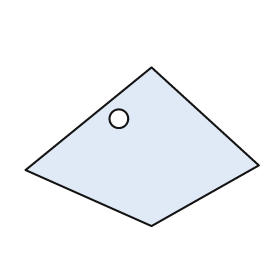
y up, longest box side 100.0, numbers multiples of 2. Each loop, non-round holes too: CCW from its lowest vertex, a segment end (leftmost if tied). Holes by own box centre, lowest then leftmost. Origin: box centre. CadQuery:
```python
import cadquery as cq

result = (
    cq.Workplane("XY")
    .moveTo(4.0, -34.0)
    .lineTo(50.0, -8.0)
    .lineTo(4.0, 34.0)
    .lineTo(-50.0, -10.0)
    .close()
    .moveTo(-10.0, 12.0)
    .circle(4.0)
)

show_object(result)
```